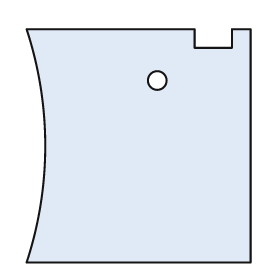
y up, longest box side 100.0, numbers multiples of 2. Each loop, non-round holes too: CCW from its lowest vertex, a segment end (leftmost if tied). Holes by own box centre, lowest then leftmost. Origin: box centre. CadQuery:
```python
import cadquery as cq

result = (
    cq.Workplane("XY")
    .moveTo(-48.0, -50.0)
    .lineTo(48.0, -50.0)
    .lineTo(48.0, 50.0)
    .lineTo(40.0, 50.0)
    .lineTo(40.0, 42.0)
    .lineTo(24.0, 42.0)
    .lineTo(24.0, 50.0)
    .lineTo(-48.0, 50.0)
    .threePointArc((-40.0, 0.0), (-48.0, -50.0))
    .close()
    .moveTo(8.0, 28.0)
    .circle(4.0)
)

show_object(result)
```